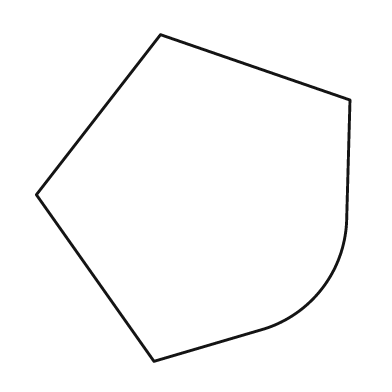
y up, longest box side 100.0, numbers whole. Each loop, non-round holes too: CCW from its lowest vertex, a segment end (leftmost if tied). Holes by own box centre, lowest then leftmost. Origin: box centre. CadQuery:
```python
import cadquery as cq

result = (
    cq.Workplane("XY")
    .moveTo(-12.0, -50.0)
    .lineTo(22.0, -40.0)
    .threePointArc((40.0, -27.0), (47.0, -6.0))
    .lineTo(48.0, 30.0)
    .lineTo(-10.0, 50.0)
    .lineTo(-48.0, 1.0)
    .close()
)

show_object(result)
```